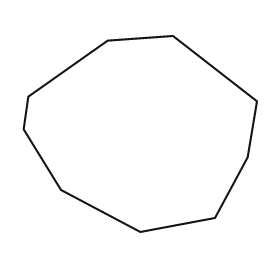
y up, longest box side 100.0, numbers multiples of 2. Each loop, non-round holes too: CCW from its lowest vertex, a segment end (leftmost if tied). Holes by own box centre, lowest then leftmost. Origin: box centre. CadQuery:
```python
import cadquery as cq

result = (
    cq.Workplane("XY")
    .moveTo(0.0, -42.0)
    .lineTo(32.0, -36.0)
    .lineTo(46.0, -10.0)
    .lineTo(50.0, 14.0)
    .lineTo(14.0, 42.0)
    .lineTo(-14.0, 40.0)
    .lineTo(-48.0, 16.0)
    .lineTo(-50.0, 2.0)
    .lineTo(-34.0, -24.0)
    .close()
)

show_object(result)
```